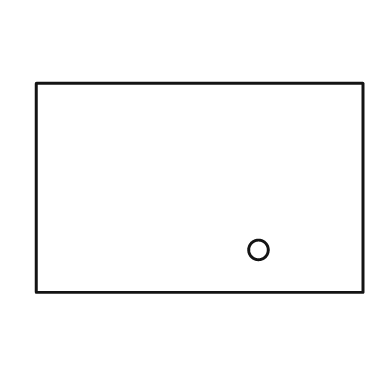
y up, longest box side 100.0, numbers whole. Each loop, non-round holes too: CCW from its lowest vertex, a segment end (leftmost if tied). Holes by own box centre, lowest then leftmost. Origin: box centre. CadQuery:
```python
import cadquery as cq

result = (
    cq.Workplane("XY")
    .moveTo(-50.0, -32.0)
    .lineTo(50.0, -32.0)
    .lineTo(50.0, 32.0)
    .lineTo(-50.0, 32.0)
    .close()
    .moveTo(18.0, -19.0)
    .circle(3.0)
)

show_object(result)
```